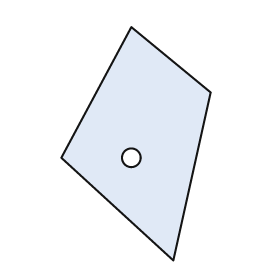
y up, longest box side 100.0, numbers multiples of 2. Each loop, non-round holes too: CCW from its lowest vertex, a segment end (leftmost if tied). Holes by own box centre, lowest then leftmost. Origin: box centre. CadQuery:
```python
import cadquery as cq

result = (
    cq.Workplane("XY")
    .moveTo(16.0, -50.0)
    .lineTo(32.0, 22.0)
    .lineTo(-2.0, 50.0)
    .lineTo(-32.0, -6.0)
    .close()
    .moveTo(-2.0, -6.0)
    .circle(4.0)
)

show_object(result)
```